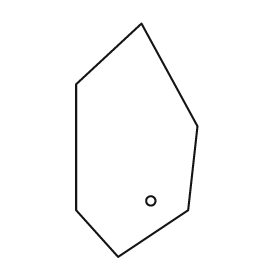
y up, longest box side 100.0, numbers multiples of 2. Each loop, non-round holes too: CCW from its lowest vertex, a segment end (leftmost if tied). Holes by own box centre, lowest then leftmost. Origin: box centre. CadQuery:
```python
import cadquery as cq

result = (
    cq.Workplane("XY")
    .moveTo(-8.0, -50.0)
    .lineTo(22.0, -30.0)
    .lineTo(26.0, 6.0)
    .lineTo(2.0, 50.0)
    .lineTo(-26.0, 24.0)
    .lineTo(-26.0, -30.0)
    .close()
    .moveTo(6.0, -26.0)
    .circle(2.0)
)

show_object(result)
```